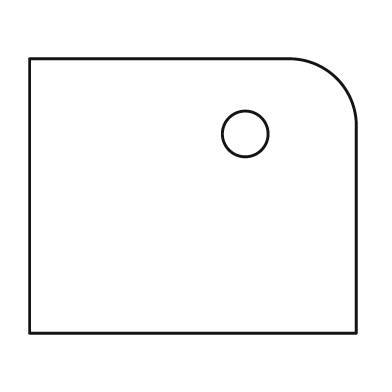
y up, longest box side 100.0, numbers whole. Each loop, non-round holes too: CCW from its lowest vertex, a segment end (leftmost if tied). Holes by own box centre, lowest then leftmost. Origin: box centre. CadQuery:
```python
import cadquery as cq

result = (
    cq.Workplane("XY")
    .moveTo(-50.0, -42.0)
    .lineTo(50.0, -42.0)
    .lineTo(50.0, 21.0)
    .threePointArc((44.0, 36.0), (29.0, 42.0))
    .lineTo(-50.0, 42.0)
    .close()
    .moveTo(16.0, 19.0)
    .circle(7.0)
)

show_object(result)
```